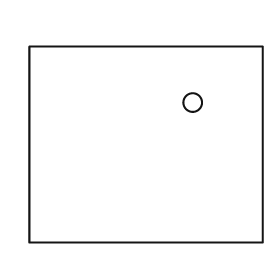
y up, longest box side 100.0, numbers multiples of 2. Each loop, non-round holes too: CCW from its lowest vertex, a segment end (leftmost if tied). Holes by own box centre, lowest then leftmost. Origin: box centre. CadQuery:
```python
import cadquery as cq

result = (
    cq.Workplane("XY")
    .moveTo(-50.0, -42.0)
    .lineTo(50.0, -42.0)
    .lineTo(50.0, 42.0)
    .lineTo(-50.0, 42.0)
    .close()
    .moveTo(20.0, 18.0)
    .circle(4.0)
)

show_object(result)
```